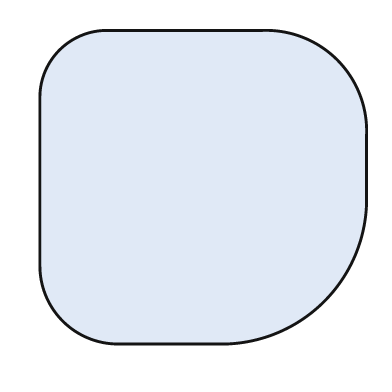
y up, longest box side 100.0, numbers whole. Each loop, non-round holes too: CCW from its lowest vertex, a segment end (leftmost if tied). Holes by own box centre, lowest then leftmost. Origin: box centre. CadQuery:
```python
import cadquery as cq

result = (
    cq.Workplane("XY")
    .moveTo(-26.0, -48.0)
    .lineTo(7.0, -48.0)
    .threePointArc((37.0, -35.0), (50.0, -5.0))
    .lineTo(50.0, 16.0)
    .threePointArc((41.0, 39.0), (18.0, 48.0))
    .lineTo(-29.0, 48.0)
    .threePointArc((-44.0, 42.0), (-50.0, 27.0))
    .lineTo(-50.0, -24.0)
    .threePointArc((-43.0, -41.0), (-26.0, -48.0))
    .close()
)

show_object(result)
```